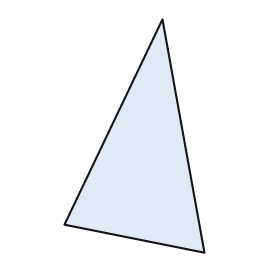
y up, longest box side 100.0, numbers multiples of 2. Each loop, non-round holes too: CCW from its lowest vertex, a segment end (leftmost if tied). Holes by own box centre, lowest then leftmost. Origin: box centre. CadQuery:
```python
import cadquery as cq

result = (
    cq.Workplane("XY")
    .moveTo(30.0, -50.0)
    .lineTo(12.0, 50.0)
    .lineTo(-30.0, -38.0)
    .close()
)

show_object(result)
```